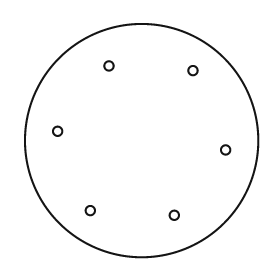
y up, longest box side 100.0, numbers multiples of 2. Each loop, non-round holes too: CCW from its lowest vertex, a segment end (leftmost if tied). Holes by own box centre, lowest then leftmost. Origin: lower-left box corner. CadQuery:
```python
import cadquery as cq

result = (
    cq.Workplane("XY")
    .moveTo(50.0, 50.0)
    .circle(50.0)
    .moveTo(64.0, 18.0)
    .circle(2.0)
    .moveTo(28.0, 20.0)
    .circle(2.0)
    .moveTo(86.0, 46.0)
    .circle(2.0)
    .moveTo(14.0, 54.0)
    .circle(2.0)
    .moveTo(72.0, 80.0)
    .circle(2.0)
    .moveTo(36.0, 82.0)
    .circle(2.0)
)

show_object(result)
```